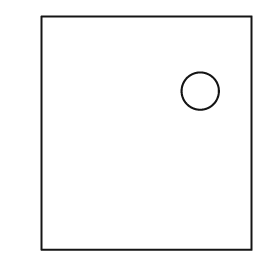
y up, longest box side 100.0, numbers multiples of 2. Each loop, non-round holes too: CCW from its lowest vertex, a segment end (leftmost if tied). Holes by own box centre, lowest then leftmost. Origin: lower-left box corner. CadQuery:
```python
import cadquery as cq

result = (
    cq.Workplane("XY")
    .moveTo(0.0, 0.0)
    .lineTo(90.0, 0.0)
    .lineTo(90.0, 100.0)
    .lineTo(0.0, 100.0)
    .close()
    .moveTo(68.0, 68.0)
    .circle(8.0)
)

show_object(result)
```